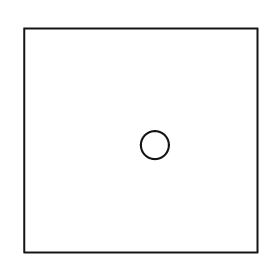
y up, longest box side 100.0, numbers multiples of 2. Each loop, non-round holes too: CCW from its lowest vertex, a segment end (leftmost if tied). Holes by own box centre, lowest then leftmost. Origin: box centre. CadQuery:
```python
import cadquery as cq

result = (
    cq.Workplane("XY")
    .moveTo(-50.0, -48.0)
    .lineTo(50.0, -48.0)
    .lineTo(50.0, 48.0)
    .lineTo(-50.0, 48.0)
    .close()
    .moveTo(6.0, -2.0)
    .circle(6.0)
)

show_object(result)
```